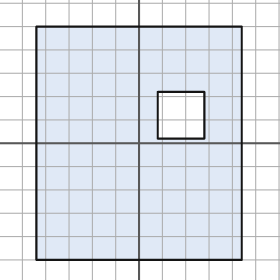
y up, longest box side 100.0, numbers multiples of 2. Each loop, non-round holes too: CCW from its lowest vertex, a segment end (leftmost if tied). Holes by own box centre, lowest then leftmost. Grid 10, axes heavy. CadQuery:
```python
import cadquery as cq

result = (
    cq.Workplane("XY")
    .moveTo(-44.0, -50.0)
    .lineTo(44.0, -50.0)
    .lineTo(44.0, 50.0)
    .lineTo(-44.0, 50.0)
    .close()
    .moveTo(8.0, 2.0)
    .lineTo(28.0, 2.0)
    .lineTo(28.0, 22.0)
    .lineTo(8.0, 22.0)
    .close()
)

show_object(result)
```